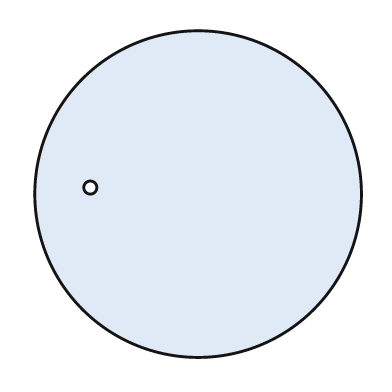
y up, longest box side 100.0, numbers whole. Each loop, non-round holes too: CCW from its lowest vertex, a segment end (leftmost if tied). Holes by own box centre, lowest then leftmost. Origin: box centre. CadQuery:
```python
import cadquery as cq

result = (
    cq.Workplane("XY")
    .moveTo(0.0, 0.0)
    .circle(50.0)
    .moveTo(-33.0, 2.0)
    .circle(2.0)
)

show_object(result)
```